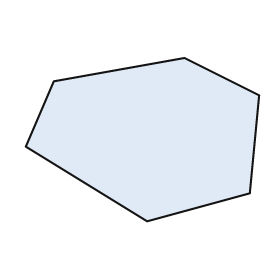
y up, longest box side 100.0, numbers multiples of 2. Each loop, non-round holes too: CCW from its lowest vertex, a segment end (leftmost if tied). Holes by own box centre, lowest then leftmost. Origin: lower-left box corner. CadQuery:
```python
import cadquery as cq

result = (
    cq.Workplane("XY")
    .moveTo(52.0, 0.0)
    .lineTo(96.0, 12.0)
    .lineTo(100.0, 54.0)
    .lineTo(68.0, 70.0)
    .lineTo(12.0, 60.0)
    .lineTo(0.0, 32.0)
    .close()
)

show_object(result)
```